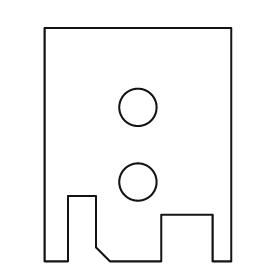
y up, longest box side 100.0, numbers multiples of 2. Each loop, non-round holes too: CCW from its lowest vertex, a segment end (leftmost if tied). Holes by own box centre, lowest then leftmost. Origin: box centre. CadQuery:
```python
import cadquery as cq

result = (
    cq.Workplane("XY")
    .moveTo(-40.0, -50.0)
    .lineTo(-30.0, -50.0)
    .lineTo(-30.0, -22.0)
    .lineTo(-18.0, -22.0)
    .lineTo(-18.0, -44.0)
    .lineTo(-12.0, -50.0)
    .lineTo(10.0, -50.0)
    .lineTo(10.0, -30.0)
    .lineTo(32.0, -30.0)
    .lineTo(32.0, -50.0)
    .lineTo(40.0, -50.0)
    .lineTo(40.0, 50.0)
    .lineTo(-40.0, 50.0)
    .close()
    .moveTo(0.0, -16.0)
    .circle(8.0)
    .moveTo(0.0, 16.0)
    .circle(8.0)
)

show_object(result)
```